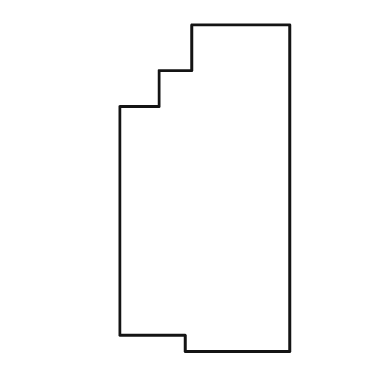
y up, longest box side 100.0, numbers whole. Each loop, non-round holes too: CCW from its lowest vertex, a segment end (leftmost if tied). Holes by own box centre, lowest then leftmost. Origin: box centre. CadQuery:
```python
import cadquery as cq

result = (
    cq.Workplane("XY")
    .moveTo(-6.0, -50.0)
    .lineTo(26.0, -50.0)
    .lineTo(26.0, 50.0)
    .lineTo(-4.0, 50.0)
    .lineTo(-4.0, 36.0)
    .lineTo(-14.0, 36.0)
    .lineTo(-14.0, 25.0)
    .lineTo(-26.0, 25.0)
    .lineTo(-26.0, -45.0)
    .lineTo(-6.0, -45.0)
    .close()
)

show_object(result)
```